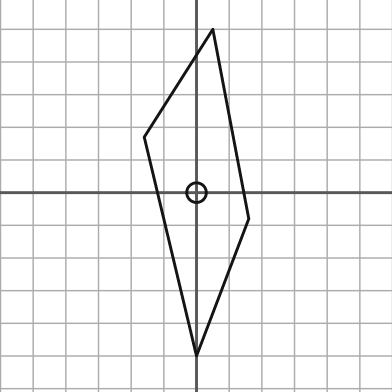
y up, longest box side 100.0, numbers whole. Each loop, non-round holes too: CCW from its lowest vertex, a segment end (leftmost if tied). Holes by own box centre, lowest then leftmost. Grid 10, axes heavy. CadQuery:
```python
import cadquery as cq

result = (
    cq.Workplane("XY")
    .moveTo(0.0, -50.0)
    .lineTo(16.0, -8.0)
    .lineTo(5.0, 50.0)
    .lineTo(-16.0, 17.0)
    .close()
    .moveTo(0.0, 0.0)
    .circle(3.0)
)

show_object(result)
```